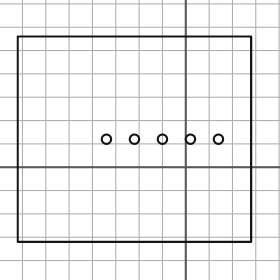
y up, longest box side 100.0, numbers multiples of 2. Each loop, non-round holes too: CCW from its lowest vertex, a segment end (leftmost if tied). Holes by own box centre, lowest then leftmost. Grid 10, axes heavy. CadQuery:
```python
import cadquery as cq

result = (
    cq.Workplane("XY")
    .moveTo(-72.0, -32.0)
    .lineTo(28.0, -32.0)
    .lineTo(28.0, 56.0)
    .lineTo(-72.0, 56.0)
    .close()
    .moveTo(-34.0, 12.0)
    .circle(2.0)
    .moveTo(-22.0, 12.0)
    .circle(2.0)
    .moveTo(-10.0, 12.0)
    .circle(2.0)
    .moveTo(2.0, 12.0)
    .circle(2.0)
    .moveTo(14.0, 12.0)
    .circle(2.0)
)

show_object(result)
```